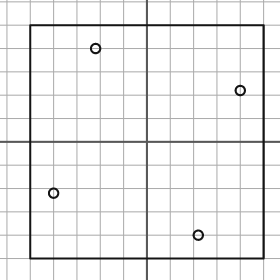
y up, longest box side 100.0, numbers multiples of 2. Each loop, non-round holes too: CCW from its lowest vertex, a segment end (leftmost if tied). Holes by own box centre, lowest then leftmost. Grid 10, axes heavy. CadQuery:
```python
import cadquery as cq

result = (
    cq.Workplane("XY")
    .moveTo(-50.0, -50.0)
    .lineTo(50.0, -50.0)
    .lineTo(50.0, 50.0)
    .lineTo(-50.0, 50.0)
    .close()
    .moveTo(22.0, -40.0)
    .circle(2.0)
    .moveTo(-40.0, -22.0)
    .circle(2.0)
    .moveTo(40.0, 22.0)
    .circle(2.0)
    .moveTo(-22.0, 40.0)
    .circle(2.0)
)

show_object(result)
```